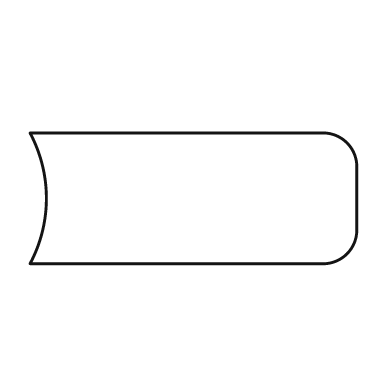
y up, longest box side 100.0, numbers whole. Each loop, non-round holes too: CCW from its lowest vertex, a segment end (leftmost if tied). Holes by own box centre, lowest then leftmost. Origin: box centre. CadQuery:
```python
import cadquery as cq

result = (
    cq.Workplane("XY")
    .moveTo(-50.0, -20.0)
    .lineTo(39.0, -20.0)
    .threePointArc((47.0, -17.0), (50.0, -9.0))
    .lineTo(50.0, 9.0)
    .threePointArc((47.0, 17.0), (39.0, 20.0))
    .lineTo(-50.0, 20.0)
    .threePointArc((-45.0, 0.0), (-50.0, -20.0))
    .close()
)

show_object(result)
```